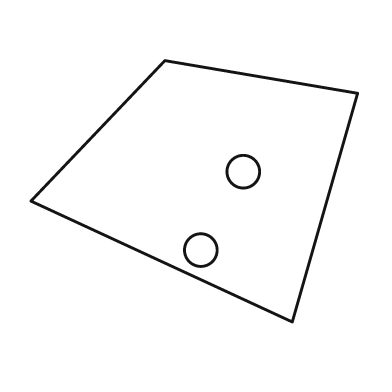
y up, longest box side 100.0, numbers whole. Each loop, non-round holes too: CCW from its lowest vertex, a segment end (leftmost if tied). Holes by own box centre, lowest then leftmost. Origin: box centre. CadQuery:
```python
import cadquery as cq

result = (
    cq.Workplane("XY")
    .moveTo(30.0, -40.0)
    .lineTo(50.0, 30.0)
    .lineTo(-9.0, 40.0)
    .lineTo(-50.0, -3.0)
    .close()
    .moveTo(2.0, -18.0)
    .circle(5.0)
    .moveTo(15.0, 6.0)
    .circle(5.0)
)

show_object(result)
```